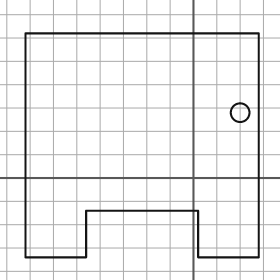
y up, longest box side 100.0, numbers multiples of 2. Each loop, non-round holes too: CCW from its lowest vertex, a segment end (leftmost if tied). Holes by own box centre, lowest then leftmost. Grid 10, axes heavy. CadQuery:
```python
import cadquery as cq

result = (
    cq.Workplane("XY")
    .moveTo(-72.0, -34.0)
    .lineTo(-46.0, -34.0)
    .lineTo(-46.0, -14.0)
    .lineTo(2.0, -14.0)
    .lineTo(2.0, -34.0)
    .lineTo(28.0, -34.0)
    .lineTo(28.0, 62.0)
    .lineTo(-72.0, 62.0)
    .close()
    .moveTo(20.0, 28.0)
    .circle(4.0)
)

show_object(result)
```